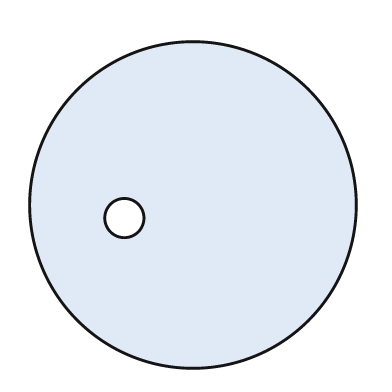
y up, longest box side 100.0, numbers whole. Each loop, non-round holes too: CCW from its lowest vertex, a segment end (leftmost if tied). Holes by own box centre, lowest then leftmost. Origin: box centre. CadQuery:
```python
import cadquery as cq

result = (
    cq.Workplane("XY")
    .moveTo(0.0, 0.0)
    .circle(50.0)
    .moveTo(-21.0, -4.0)
    .circle(6.0)
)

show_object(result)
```